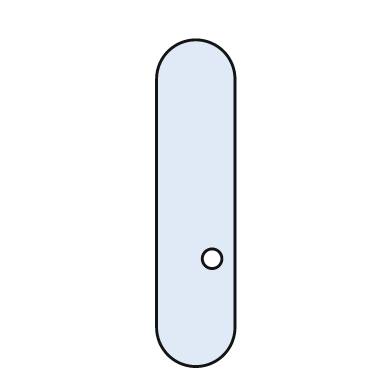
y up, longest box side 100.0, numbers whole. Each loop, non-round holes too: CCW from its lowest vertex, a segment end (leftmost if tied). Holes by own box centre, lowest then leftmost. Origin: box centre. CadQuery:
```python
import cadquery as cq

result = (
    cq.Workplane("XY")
    .moveTo(-12.0, -38.0)
    .threePointArc((0.0, -50.0), (12.0, -38.0))
    .lineTo(12.0, 38.0)
    .threePointArc((0.0, 50.0), (-12.0, 38.0))
    .close()
    .moveTo(5.0, -17.0)
    .circle(3.0)
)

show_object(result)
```